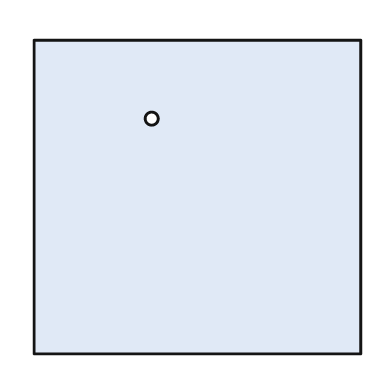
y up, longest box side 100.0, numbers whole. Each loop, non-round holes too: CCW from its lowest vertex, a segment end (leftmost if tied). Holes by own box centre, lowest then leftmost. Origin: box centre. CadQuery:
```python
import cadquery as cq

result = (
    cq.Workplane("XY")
    .moveTo(-50.0, -48.0)
    .lineTo(50.0, -48.0)
    .lineTo(50.0, 48.0)
    .lineTo(-50.0, 48.0)
    .close()
    .moveTo(-14.0, 24.0)
    .circle(2.0)
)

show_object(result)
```